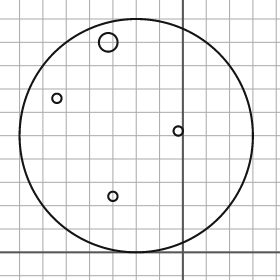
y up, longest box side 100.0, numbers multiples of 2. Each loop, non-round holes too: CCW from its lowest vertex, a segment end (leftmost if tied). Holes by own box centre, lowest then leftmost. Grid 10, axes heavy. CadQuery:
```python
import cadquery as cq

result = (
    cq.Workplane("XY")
    .moveTo(-20.0, 50.0)
    .circle(50.0)
    .moveTo(-30.0, 24.0)
    .circle(2.0)
    .moveTo(-2.0, 52.0)
    .circle(2.0)
    .moveTo(-54.0, 66.0)
    .circle(2.0)
    .moveTo(-32.0, 90.0)
    .circle(4.0)
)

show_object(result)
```